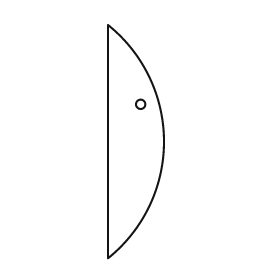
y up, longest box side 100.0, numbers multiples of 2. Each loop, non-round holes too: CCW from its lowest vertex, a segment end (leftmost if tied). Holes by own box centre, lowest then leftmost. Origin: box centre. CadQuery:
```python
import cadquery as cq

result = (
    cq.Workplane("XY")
    .moveTo(-12.0, -50.0)
    .threePointArc((12.0, 0.0), (-12.0, 50.0))
    .close()
    .moveTo(2.0, 16.0)
    .circle(2.0)
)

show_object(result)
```